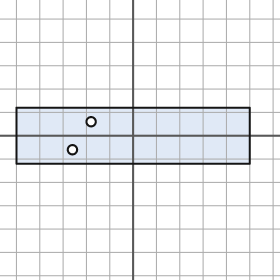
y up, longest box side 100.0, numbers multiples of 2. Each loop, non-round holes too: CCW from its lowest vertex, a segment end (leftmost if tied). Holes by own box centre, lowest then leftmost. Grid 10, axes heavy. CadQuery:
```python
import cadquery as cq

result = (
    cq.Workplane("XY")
    .moveTo(-50.0, -12.0)
    .lineTo(50.0, -12.0)
    .lineTo(50.0, 12.0)
    .lineTo(-50.0, 12.0)
    .close()
    .moveTo(-26.0, -6.0)
    .circle(2.0)
    .moveTo(-18.0, 6.0)
    .circle(2.0)
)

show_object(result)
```